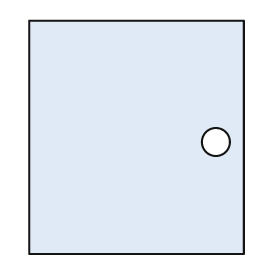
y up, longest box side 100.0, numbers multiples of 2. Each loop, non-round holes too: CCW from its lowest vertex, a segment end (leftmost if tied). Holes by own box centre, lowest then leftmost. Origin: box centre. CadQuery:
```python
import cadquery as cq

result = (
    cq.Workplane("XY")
    .moveTo(-46.0, -50.0)
    .lineTo(46.0, -50.0)
    .lineTo(46.0, 50.0)
    .lineTo(-46.0, 50.0)
    .close()
    .moveTo(34.0, -2.0)
    .circle(6.0)
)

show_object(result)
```